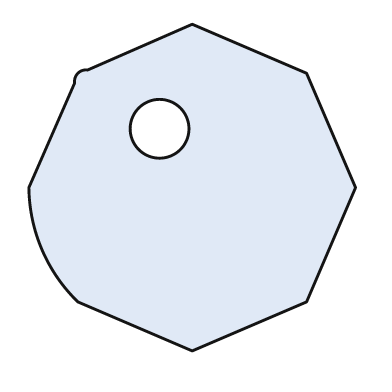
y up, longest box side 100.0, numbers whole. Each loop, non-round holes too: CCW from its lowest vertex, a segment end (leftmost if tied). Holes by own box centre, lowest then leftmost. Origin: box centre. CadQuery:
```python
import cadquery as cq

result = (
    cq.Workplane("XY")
    .moveTo(0.0, -50.0)
    .lineTo(35.0, -35.0)
    .lineTo(50.0, 0.0)
    .lineTo(35.0, 35.0)
    .lineTo(0.0, 50.0)
    .lineTo(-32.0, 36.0)
    .threePointArc((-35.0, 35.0), (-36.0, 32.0))
    .lineTo(-50.0, 0.0)
    .threePointArc((-46.0, -19.0), (-35.0, -35.0))
    .close()
    .moveTo(-10.0, 18.0)
    .circle(9.0)
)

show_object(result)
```